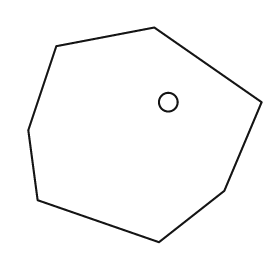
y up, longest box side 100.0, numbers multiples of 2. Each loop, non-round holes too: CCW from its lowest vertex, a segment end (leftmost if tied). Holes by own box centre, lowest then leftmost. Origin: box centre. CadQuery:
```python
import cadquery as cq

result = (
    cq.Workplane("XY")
    .moveTo(6.0, -46.0)
    .lineTo(34.0, -24.0)
    .lineTo(50.0, 14.0)
    .lineTo(4.0, 46.0)
    .lineTo(-38.0, 38.0)
    .lineTo(-50.0, 2.0)
    .lineTo(-46.0, -28.0)
    .close()
    .moveTo(10.0, 14.0)
    .circle(4.0)
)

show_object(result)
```